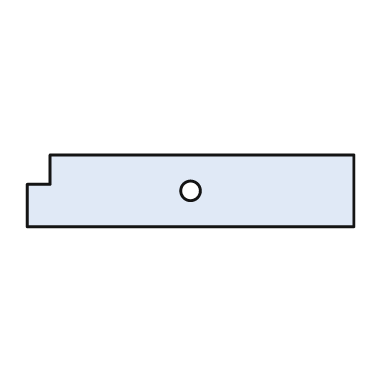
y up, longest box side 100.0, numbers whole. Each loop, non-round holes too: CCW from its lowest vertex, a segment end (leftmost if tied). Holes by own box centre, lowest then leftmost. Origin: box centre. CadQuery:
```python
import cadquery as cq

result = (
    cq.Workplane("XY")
    .moveTo(-50.0, -11.0)
    .lineTo(50.0, -11.0)
    .lineTo(50.0, 11.0)
    .lineTo(-43.0, 11.0)
    .lineTo(-43.0, 2.0)
    .lineTo(-50.0, 2.0)
    .close()
    .moveTo(0.0, 0.0)
    .circle(3.0)
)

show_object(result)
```